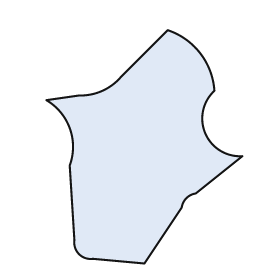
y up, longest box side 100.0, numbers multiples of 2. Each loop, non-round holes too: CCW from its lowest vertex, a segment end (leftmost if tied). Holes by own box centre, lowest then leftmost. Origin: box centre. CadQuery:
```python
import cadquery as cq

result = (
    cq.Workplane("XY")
    .moveTo(0.0, -50.0)
    .lineTo(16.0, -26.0)
    .threePointArc((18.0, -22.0), (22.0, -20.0))
    .lineTo(42.0, -4.0)
    .threePointArc((26.0, 6.0), (30.0, 24.0))
    .threePointArc((24.0, 40.0), (10.0, 50.0))
    .lineTo(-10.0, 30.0)
    .threePointArc((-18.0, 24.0), (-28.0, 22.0))
    .lineTo(-42.0, 20.0)
    .threePointArc((-32.0, 8.0), (-32.0, -8.0))
    .lineTo(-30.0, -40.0)
    .threePointArc((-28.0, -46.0), (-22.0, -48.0))
    .close()
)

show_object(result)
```